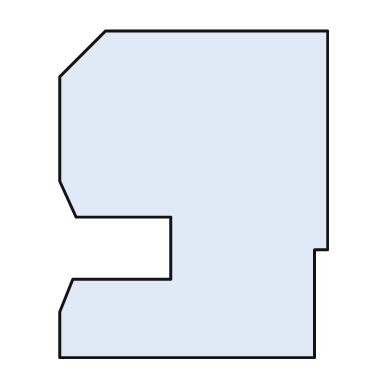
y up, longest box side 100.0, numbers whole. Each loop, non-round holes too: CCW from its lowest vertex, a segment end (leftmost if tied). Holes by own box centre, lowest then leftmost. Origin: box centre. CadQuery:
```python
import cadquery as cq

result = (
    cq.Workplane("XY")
    .moveTo(-41.0, -50.0)
    .lineTo(37.0, -50.0)
    .lineTo(37.0, -17.0)
    .lineTo(41.0, -17.0)
    .lineTo(41.0, 50.0)
    .lineTo(-27.0, 50.0)
    .lineTo(-41.0, 36.0)
    .lineTo(-41.0, 4.0)
    .lineTo(-36.0, -7.0)
    .lineTo(-7.0, -7.0)
    .lineTo(-7.0, -26.0)
    .lineTo(-37.0, -26.0)
    .lineTo(-41.0, -36.0)
    .close()
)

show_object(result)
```